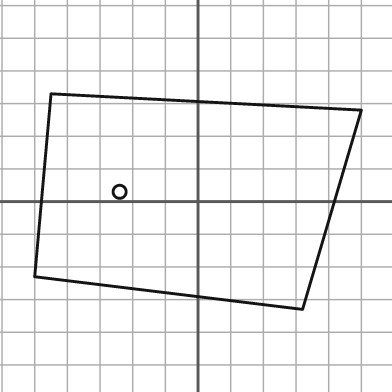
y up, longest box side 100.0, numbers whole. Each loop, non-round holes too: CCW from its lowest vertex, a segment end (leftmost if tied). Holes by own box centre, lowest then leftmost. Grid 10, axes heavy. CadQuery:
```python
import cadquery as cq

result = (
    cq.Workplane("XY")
    .moveTo(32.0, -33.0)
    .lineTo(50.0, 28.0)
    .lineTo(-45.0, 33.0)
    .lineTo(-50.0, -23.0)
    .close()
    .moveTo(-24.0, 3.0)
    .circle(2.0)
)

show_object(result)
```